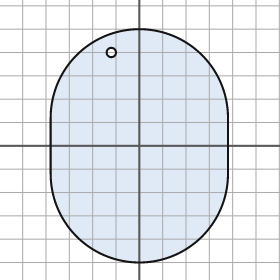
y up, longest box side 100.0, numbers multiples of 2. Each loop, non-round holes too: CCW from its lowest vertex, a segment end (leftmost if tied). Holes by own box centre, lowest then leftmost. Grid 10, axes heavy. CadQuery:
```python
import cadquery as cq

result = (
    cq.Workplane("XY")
    .moveTo(-38.0, -12.0)
    .threePointArc((0.0, -50.0), (38.0, -12.0))
    .lineTo(38.0, 12.0)
    .threePointArc((0.0, 50.0), (-38.0, 12.0))
    .close()
    .moveTo(-12.0, 40.0)
    .circle(2.0)
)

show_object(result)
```